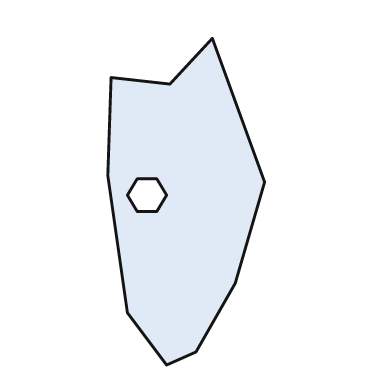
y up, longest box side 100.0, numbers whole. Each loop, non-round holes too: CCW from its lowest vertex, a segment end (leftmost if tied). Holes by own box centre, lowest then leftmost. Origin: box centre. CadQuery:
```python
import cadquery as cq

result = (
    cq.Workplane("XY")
    .moveTo(-6.0, -50.0)
    .lineTo(3.0, -46.0)
    .lineTo(15.0, -25.0)
    .lineTo(24.0, 6.0)
    .lineTo(8.0, 50.0)
    .lineTo(-5.0, 36.0)
    .lineTo(-23.0, 38.0)
    .lineTo(-24.0, 8.0)
    .lineTo(-18.0, -34.0)
    .close()
    .moveTo(-15.0, -3.0)
    .lineTo(-9.0, -3.0)
    .lineTo(-6.0, 2.0)
    .lineTo(-9.0, 7.0)
    .lineTo(-15.0, 7.0)
    .lineTo(-18.0, 2.0)
    .close()
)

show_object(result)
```